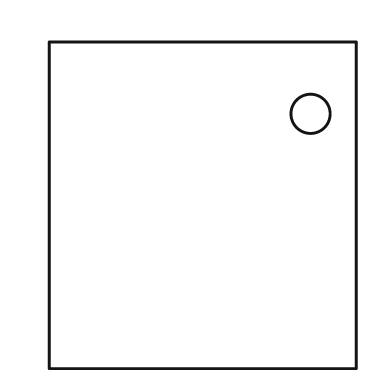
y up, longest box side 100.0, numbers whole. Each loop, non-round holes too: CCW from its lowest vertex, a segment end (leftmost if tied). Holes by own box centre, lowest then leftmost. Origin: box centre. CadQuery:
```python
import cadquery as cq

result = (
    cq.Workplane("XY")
    .moveTo(-47.0, -50.0)
    .lineTo(47.0, -50.0)
    .lineTo(47.0, 50.0)
    .lineTo(-47.0, 50.0)
    .close()
    .moveTo(33.0, 28.0)
    .circle(6.0)
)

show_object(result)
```